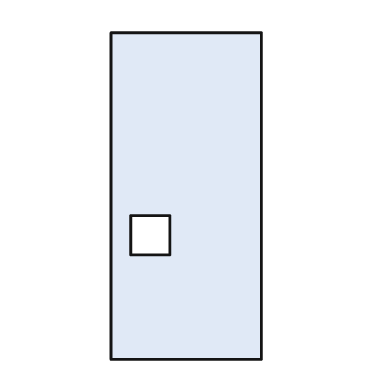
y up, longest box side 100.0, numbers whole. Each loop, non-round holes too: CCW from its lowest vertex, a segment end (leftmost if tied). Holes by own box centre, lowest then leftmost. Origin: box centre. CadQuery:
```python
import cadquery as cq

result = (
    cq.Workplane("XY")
    .moveTo(-23.0, -50.0)
    .lineTo(23.0, -50.0)
    .lineTo(23.0, 50.0)
    .lineTo(-23.0, 50.0)
    .close()
    .moveTo(-17.0, -18.0)
    .lineTo(-5.0, -18.0)
    .lineTo(-5.0, -6.0)
    .lineTo(-17.0, -6.0)
    .close()
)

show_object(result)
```